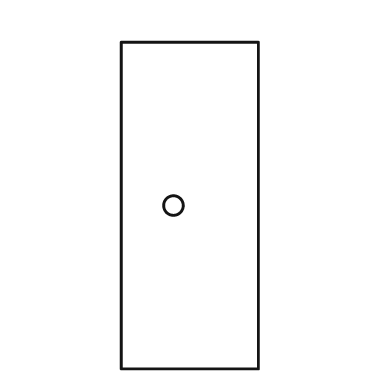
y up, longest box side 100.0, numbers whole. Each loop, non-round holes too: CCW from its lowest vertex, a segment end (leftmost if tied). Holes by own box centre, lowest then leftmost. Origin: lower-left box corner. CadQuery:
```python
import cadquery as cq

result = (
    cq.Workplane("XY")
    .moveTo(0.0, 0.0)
    .lineTo(42.0, 0.0)
    .lineTo(42.0, 100.0)
    .lineTo(0.0, 100.0)
    .close()
    .moveTo(16.0, 50.0)
    .circle(3.0)
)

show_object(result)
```